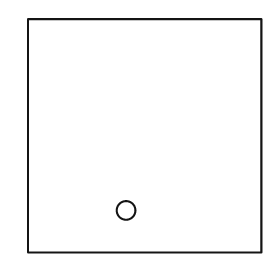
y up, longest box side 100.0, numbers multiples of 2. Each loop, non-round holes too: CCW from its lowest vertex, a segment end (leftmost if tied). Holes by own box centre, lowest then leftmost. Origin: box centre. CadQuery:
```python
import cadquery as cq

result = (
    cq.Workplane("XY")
    .moveTo(-50.0, -50.0)
    .lineTo(50.0, -50.0)
    .lineTo(50.0, 50.0)
    .lineTo(-50.0, 50.0)
    .close()
    .moveTo(-8.0, -32.0)
    .circle(4.0)
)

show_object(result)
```